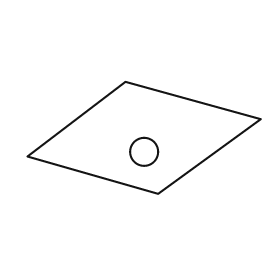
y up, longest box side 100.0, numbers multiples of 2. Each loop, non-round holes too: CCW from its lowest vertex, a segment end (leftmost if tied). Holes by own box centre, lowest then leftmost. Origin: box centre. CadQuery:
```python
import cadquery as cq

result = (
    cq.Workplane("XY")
    .moveTo(6.0, -24.0)
    .lineTo(50.0, 8.0)
    .lineTo(-8.0, 24.0)
    .lineTo(-50.0, -8.0)
    .close()
    .moveTo(0.0, -6.0)
    .circle(6.0)
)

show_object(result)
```